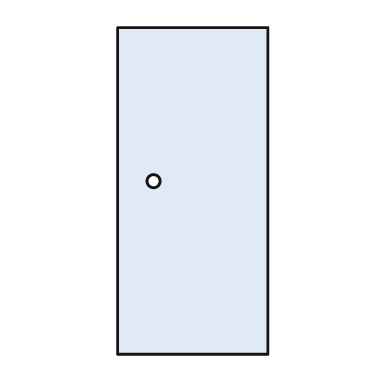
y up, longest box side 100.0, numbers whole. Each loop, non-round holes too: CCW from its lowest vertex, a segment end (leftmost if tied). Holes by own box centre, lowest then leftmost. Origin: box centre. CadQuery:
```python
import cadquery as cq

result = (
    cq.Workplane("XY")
    .moveTo(-23.0, -50.0)
    .lineTo(23.0, -50.0)
    .lineTo(23.0, 50.0)
    .lineTo(-23.0, 50.0)
    .close()
    .moveTo(-12.0, 3.0)
    .circle(2.0)
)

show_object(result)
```